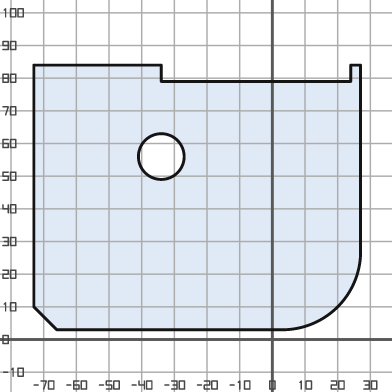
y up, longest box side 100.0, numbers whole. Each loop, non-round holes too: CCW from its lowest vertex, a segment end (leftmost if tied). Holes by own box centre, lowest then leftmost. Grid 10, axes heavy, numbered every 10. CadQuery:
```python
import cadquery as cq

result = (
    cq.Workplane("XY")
    .moveTo(-66.0, 3.0)
    .lineTo(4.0, 3.0)
    .threePointArc((20.0, 10.0), (27.0, 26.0))
    .lineTo(27.0, 84.0)
    .lineTo(24.0, 84.0)
    .lineTo(24.0, 79.0)
    .lineTo(-34.0, 79.0)
    .lineTo(-34.0, 84.0)
    .lineTo(-73.0, 84.0)
    .lineTo(-73.0, 10.0)
    .close()
    .moveTo(-34.0, 56.0)
    .circle(7.0)
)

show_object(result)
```